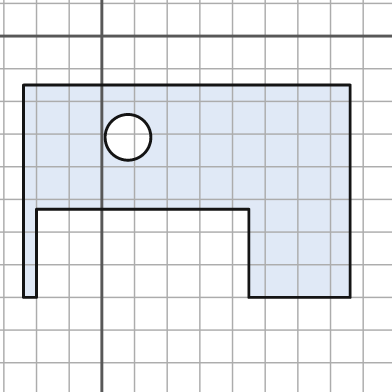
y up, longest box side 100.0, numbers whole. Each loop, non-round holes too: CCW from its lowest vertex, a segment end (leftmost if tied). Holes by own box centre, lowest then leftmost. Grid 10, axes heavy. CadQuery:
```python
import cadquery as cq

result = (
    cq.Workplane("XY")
    .moveTo(-24.0, -80.0)
    .lineTo(-20.0, -80.0)
    .lineTo(-20.0, -53.0)
    .lineTo(45.0, -53.0)
    .lineTo(45.0, -80.0)
    .lineTo(76.0, -80.0)
    .lineTo(76.0, -15.0)
    .lineTo(-24.0, -15.0)
    .close()
    .moveTo(8.0, -31.0)
    .circle(7.0)
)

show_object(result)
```